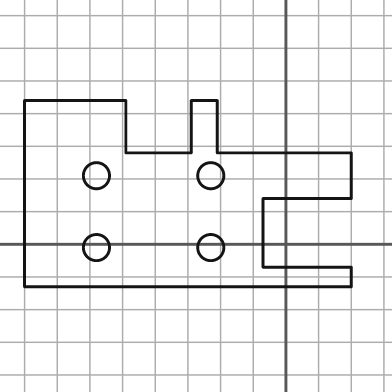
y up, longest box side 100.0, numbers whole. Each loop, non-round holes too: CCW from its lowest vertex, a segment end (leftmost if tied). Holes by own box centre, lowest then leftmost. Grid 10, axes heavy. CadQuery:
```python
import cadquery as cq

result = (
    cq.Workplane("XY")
    .moveTo(-80.0, -13.0)
    .lineTo(20.0, -13.0)
    .lineTo(20.0, -7.0)
    .lineTo(-7.0, -7.0)
    .lineTo(-7.0, 14.0)
    .lineTo(20.0, 14.0)
    .lineTo(20.0, 28.0)
    .lineTo(-21.0, 28.0)
    .lineTo(-21.0, 44.0)
    .lineTo(-29.0, 44.0)
    .lineTo(-29.0, 28.0)
    .lineTo(-49.0, 28.0)
    .lineTo(-49.0, 44.0)
    .lineTo(-80.0, 44.0)
    .close()
    .moveTo(-58.0, -1.0)
    .circle(4.0)
    .moveTo(-23.0, -1.0)
    .circle(4.0)
    .moveTo(-58.0, 21.0)
    .circle(4.0)
    .moveTo(-23.0, 21.0)
    .circle(4.0)
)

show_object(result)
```